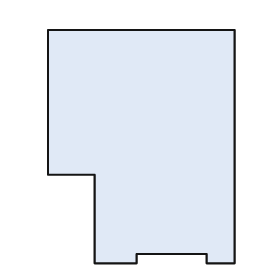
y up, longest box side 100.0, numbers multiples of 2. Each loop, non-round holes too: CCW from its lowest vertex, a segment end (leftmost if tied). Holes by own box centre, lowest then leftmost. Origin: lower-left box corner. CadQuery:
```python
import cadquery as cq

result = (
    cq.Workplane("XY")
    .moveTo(20.0, 0.0)
    .lineTo(38.0, 0.0)
    .lineTo(38.0, 4.0)
    .lineTo(68.0, 4.0)
    .lineTo(68.0, 0.0)
    .lineTo(80.0, 0.0)
    .lineTo(80.0, 100.0)
    .lineTo(0.0, 100.0)
    .lineTo(0.0, 38.0)
    .lineTo(20.0, 38.0)
    .close()
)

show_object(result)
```